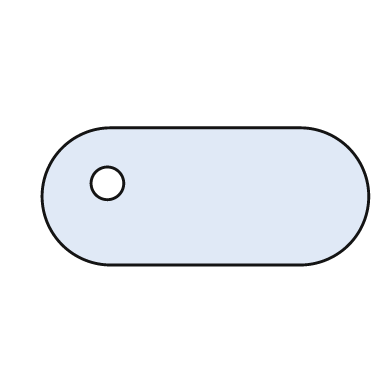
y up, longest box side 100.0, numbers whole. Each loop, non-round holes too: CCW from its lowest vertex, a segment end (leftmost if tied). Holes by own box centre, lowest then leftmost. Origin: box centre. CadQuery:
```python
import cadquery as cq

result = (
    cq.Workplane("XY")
    .moveTo(-29.0, -21.0)
    .lineTo(29.0, -21.0)
    .threePointArc((50.0, 0.0), (29.0, 21.0))
    .lineTo(-29.0, 21.0)
    .threePointArc((-50.0, 0.0), (-29.0, -21.0))
    .close()
    .moveTo(-30.0, 4.0)
    .circle(5.0)
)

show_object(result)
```